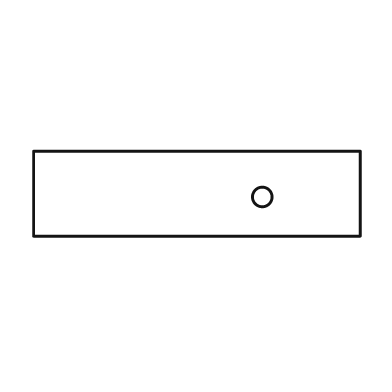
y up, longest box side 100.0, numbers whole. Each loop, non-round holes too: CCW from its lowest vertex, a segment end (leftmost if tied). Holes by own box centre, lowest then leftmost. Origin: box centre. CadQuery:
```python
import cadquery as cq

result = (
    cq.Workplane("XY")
    .moveTo(-50.0, -13.0)
    .lineTo(50.0, -13.0)
    .lineTo(50.0, 13.0)
    .lineTo(-50.0, 13.0)
    .close()
    .moveTo(20.0, -1.0)
    .circle(3.0)
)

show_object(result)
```